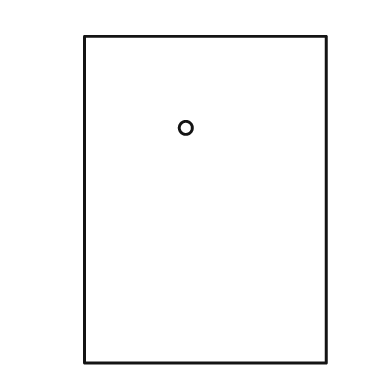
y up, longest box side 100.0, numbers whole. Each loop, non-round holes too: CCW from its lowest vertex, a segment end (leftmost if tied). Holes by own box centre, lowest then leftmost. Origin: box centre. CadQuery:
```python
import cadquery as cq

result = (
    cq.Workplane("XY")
    .moveTo(-37.0, -50.0)
    .lineTo(37.0, -50.0)
    .lineTo(37.0, 50.0)
    .lineTo(-37.0, 50.0)
    .close()
    .moveTo(-6.0, 22.0)
    .circle(2.0)
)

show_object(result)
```